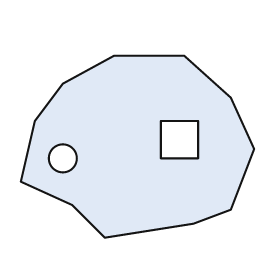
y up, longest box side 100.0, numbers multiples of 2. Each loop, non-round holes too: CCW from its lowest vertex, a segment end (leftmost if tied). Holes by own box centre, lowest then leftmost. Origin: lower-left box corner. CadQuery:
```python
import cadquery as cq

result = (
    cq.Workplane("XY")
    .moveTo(36.0, 0.0)
    .lineTo(74.0, 6.0)
    .lineTo(90.0, 12.0)
    .lineTo(100.0, 38.0)
    .lineTo(90.0, 60.0)
    .lineTo(70.0, 78.0)
    .lineTo(40.0, 78.0)
    .lineTo(18.0, 66.0)
    .lineTo(6.0, 50.0)
    .lineTo(0.0, 24.0)
    .lineTo(22.0, 14.0)
    .close()
    .moveTo(18.0, 34.0)
    .circle(6.0)
    .moveTo(60.0, 34.0)
    .lineTo(76.0, 34.0)
    .lineTo(76.0, 50.0)
    .lineTo(60.0, 50.0)
    .close()
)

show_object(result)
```